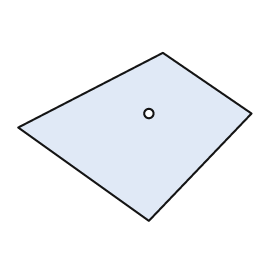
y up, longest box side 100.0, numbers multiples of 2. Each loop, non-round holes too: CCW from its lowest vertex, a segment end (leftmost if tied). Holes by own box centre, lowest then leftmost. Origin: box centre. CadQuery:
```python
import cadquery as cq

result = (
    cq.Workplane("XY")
    .moveTo(6.0, -36.0)
    .lineTo(50.0, 10.0)
    .lineTo(12.0, 36.0)
    .lineTo(-50.0, 4.0)
    .close()
    .moveTo(6.0, 10.0)
    .circle(2.0)
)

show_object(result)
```